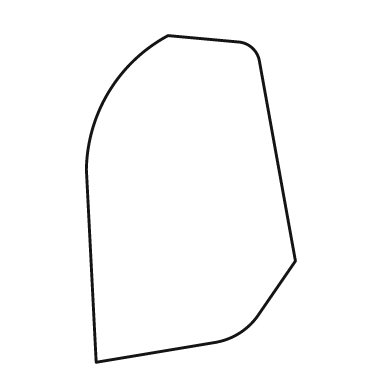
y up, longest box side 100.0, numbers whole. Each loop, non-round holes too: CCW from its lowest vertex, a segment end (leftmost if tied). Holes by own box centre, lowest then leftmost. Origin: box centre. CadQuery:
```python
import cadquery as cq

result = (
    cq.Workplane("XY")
    .moveTo(-29.0, -50.0)
    .lineTo(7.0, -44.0)
    .threePointArc((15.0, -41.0), (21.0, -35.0))
    .lineTo(32.0, -19.0)
    .lineTo(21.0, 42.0)
    .threePointArc((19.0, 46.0), (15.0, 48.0))
    .lineTo(-7.0, 50.0)
    .threePointArc((-25.0, 33.0), (-32.0, 9.0))
    .close()
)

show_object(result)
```